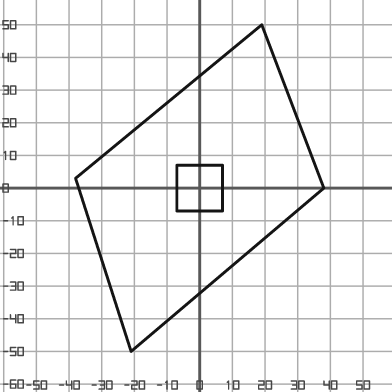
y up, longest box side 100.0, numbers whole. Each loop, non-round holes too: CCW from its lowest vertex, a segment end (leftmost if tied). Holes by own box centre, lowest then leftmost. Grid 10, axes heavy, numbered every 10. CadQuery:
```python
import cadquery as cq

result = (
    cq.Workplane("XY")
    .moveTo(-21.0, -50.0)
    .lineTo(38.0, 0.0)
    .lineTo(19.0, 50.0)
    .lineTo(-38.0, 3.0)
    .close()
    .moveTo(-7.0, -7.0)
    .lineTo(7.0, -7.0)
    .lineTo(7.0, 7.0)
    .lineTo(-7.0, 7.0)
    .close()
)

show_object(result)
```